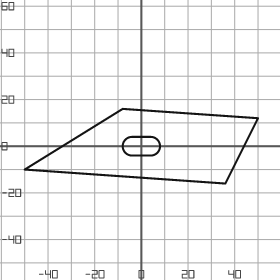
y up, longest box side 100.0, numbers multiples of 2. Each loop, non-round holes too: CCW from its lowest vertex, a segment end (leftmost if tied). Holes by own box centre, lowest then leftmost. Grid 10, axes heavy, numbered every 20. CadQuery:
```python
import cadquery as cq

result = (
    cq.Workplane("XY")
    .moveTo(36.0, -16.0)
    .lineTo(50.0, 12.0)
    .lineTo(-8.0, 16.0)
    .lineTo(-50.0, -10.0)
    .close()
    .moveTo(-4.0, -4.0)
    .lineTo(4.0, -4.0)
    .threePointArc((8.0, 0.0), (4.0, 4.0))
    .lineTo(-4.0, 4.0)
    .threePointArc((-8.0, 0.0), (-4.0, -4.0))
    .close()
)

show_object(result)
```